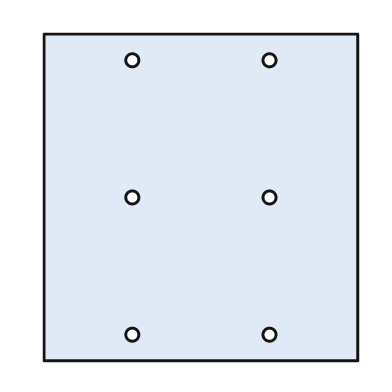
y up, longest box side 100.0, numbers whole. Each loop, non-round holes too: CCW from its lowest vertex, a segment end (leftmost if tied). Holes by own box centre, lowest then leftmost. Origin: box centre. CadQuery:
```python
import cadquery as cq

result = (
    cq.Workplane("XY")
    .moveTo(-48.0, -50.0)
    .lineTo(48.0, -50.0)
    .lineTo(48.0, 50.0)
    .lineTo(-48.0, 50.0)
    .close()
    .moveTo(-21.0, -42.0)
    .circle(2.0)
    .moveTo(21.0, -42.0)
    .circle(2.0)
    .moveTo(-21.0, 0.0)
    .circle(2.0)
    .moveTo(21.0, 0.0)
    .circle(2.0)
    .moveTo(-21.0, 42.0)
    .circle(2.0)
    .moveTo(21.0, 42.0)
    .circle(2.0)
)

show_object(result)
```